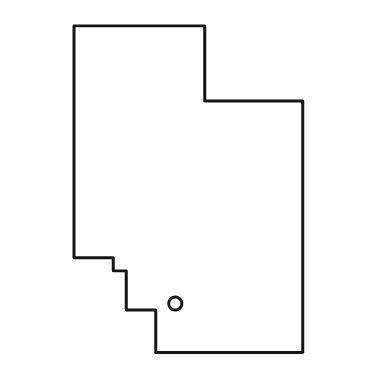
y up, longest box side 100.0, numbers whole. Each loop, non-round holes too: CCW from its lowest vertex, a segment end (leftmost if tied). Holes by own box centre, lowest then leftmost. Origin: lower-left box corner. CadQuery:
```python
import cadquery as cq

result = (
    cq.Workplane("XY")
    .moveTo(25.0, 0.0)
    .lineTo(70.0, 0.0)
    .lineTo(70.0, 77.0)
    .lineTo(40.0, 77.0)
    .lineTo(40.0, 100.0)
    .lineTo(0.0, 100.0)
    .lineTo(0.0, 29.0)
    .lineTo(12.0, 29.0)
    .lineTo(12.0, 25.0)
    .lineTo(16.0, 25.0)
    .lineTo(16.0, 13.0)
    .lineTo(25.0, 13.0)
    .close()
    .moveTo(31.0, 15.0)
    .circle(2.0)
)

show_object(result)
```